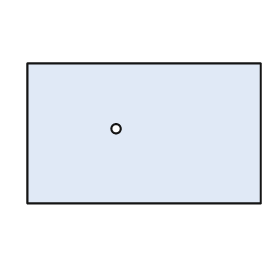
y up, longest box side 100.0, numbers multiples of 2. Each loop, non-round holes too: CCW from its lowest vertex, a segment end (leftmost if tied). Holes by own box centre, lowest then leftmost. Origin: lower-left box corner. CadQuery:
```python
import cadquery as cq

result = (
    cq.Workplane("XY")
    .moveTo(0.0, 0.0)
    .lineTo(100.0, 0.0)
    .lineTo(100.0, 60.0)
    .lineTo(0.0, 60.0)
    .close()
    .moveTo(38.0, 32.0)
    .circle(2.0)
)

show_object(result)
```